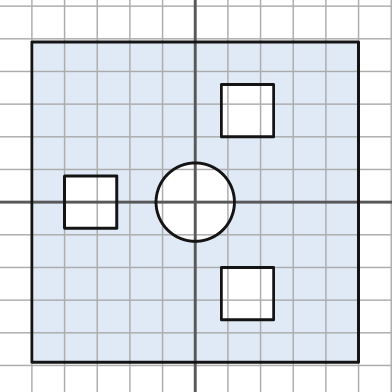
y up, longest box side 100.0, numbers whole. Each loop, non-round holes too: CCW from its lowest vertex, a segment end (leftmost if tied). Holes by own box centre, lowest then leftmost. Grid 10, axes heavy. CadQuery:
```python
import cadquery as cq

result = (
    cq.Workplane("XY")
    .moveTo(-50.0, -49.0)
    .lineTo(50.0, -49.0)
    .lineTo(50.0, 49.0)
    .lineTo(-50.0, 49.0)
    .close()
    .moveTo(8.0, -36.0)
    .lineTo(24.0, -36.0)
    .lineTo(24.0, -20.0)
    .lineTo(8.0, -20.0)
    .close()
    .moveTo(-40.0, -8.0)
    .lineTo(-24.0, -8.0)
    .lineTo(-24.0, 8.0)
    .lineTo(-40.0, 8.0)
    .close()
    .moveTo(0.0, 0.0)
    .circle(12.0)
    .moveTo(8.0, 20.0)
    .lineTo(24.0, 20.0)
    .lineTo(24.0, 36.0)
    .lineTo(8.0, 36.0)
    .close()
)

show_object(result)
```